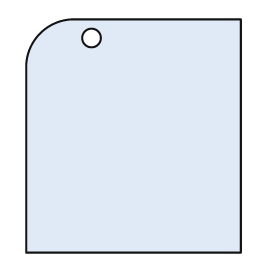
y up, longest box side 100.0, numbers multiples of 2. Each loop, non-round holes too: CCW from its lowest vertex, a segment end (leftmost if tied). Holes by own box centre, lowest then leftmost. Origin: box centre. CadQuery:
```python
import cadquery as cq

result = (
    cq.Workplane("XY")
    .moveTo(-46.0, -50.0)
    .lineTo(46.0, -50.0)
    .lineTo(46.0, 50.0)
    .lineTo(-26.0, 50.0)
    .threePointArc((-40.0, 44.0), (-46.0, 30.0))
    .close()
    .moveTo(-18.0, 42.0)
    .circle(4.0)
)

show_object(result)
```